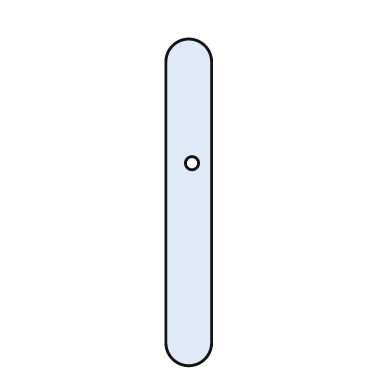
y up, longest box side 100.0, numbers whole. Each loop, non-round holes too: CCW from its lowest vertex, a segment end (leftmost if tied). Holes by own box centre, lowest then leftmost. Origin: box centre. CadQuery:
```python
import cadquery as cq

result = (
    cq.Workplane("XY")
    .moveTo(-7.0, -43.0)
    .threePointArc((0.0, -50.0), (7.0, -43.0))
    .lineTo(7.0, 43.0)
    .threePointArc((0.0, 50.0), (-7.0, 43.0))
    .close()
    .moveTo(1.0, 12.0)
    .circle(2.0)
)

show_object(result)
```